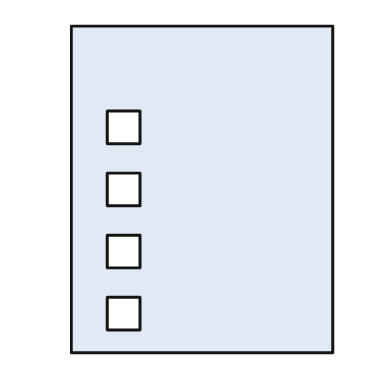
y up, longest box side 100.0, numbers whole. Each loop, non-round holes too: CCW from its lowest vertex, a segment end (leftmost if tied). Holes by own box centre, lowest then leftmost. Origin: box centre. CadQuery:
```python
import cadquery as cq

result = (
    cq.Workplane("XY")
    .moveTo(-40.0, -50.0)
    .lineTo(40.0, -50.0)
    .lineTo(40.0, 50.0)
    .lineTo(-40.0, 50.0)
    .close()
    .moveTo(-29.0, -43.0)
    .lineTo(-19.0, -43.0)
    .lineTo(-19.0, -33.0)
    .lineTo(-29.0, -33.0)
    .close()
    .moveTo(-29.0, -24.0)
    .lineTo(-19.0, -24.0)
    .lineTo(-19.0, -14.0)
    .lineTo(-29.0, -14.0)
    .close()
    .moveTo(-29.0, -5.0)
    .lineTo(-19.0, -5.0)
    .lineTo(-19.0, 5.0)
    .lineTo(-29.0, 5.0)
    .close()
    .moveTo(-29.0, 14.0)
    .lineTo(-19.0, 14.0)
    .lineTo(-19.0, 24.0)
    .lineTo(-29.0, 24.0)
    .close()
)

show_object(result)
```